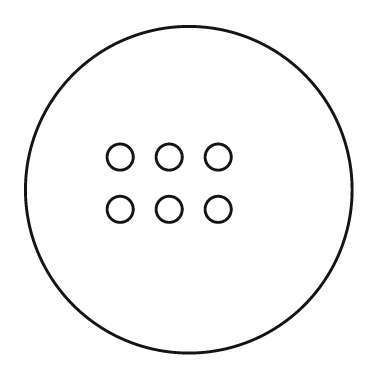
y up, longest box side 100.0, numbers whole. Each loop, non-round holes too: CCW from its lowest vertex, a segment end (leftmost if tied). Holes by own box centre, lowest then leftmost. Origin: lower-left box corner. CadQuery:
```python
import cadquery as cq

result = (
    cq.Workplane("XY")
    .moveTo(50.0, 50.0)
    .circle(50.0)
    .moveTo(29.0, 44.0)
    .circle(4.0)
    .moveTo(44.0, 44.0)
    .circle(4.0)
    .moveTo(59.0, 44.0)
    .circle(4.0)
    .moveTo(29.0, 60.0)
    .circle(4.0)
    .moveTo(44.0, 60.0)
    .circle(4.0)
    .moveTo(59.0, 60.0)
    .circle(4.0)
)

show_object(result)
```